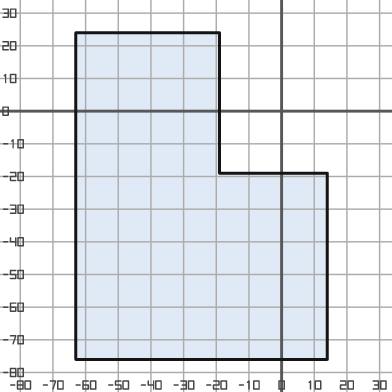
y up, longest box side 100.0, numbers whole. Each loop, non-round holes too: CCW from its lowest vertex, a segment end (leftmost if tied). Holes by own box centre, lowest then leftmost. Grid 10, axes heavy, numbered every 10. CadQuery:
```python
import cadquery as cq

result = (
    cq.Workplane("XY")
    .moveTo(-63.0, -76.0)
    .lineTo(14.0, -76.0)
    .lineTo(14.0, -19.0)
    .lineTo(-19.0, -19.0)
    .lineTo(-19.0, 24.0)
    .lineTo(-63.0, 24.0)
    .close()
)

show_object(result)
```